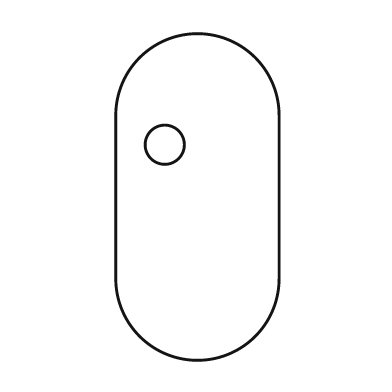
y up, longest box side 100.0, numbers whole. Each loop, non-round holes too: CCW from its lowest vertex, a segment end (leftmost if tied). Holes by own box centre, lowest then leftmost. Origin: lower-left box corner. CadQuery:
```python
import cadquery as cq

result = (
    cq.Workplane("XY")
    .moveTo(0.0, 25.0)
    .threePointArc((25.0, 0.0), (50.0, 25.0))
    .lineTo(50.0, 75.0)
    .threePointArc((25.0, 100.0), (0.0, 75.0))
    .close()
    .moveTo(15.0, 66.0)
    .circle(6.0)
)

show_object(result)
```